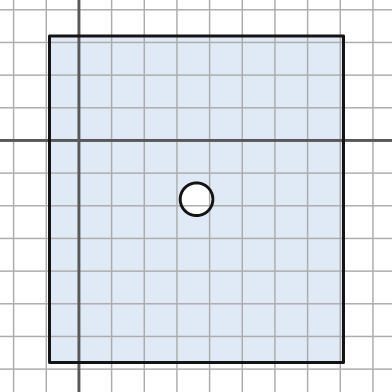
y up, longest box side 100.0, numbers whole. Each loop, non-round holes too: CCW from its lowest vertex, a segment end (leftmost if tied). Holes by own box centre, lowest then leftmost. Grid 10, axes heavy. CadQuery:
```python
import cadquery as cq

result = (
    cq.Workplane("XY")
    .moveTo(-9.0, -68.0)
    .lineTo(81.0, -68.0)
    .lineTo(81.0, 32.0)
    .lineTo(-9.0, 32.0)
    .close()
    .moveTo(36.0, -18.0)
    .circle(5.0)
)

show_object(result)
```